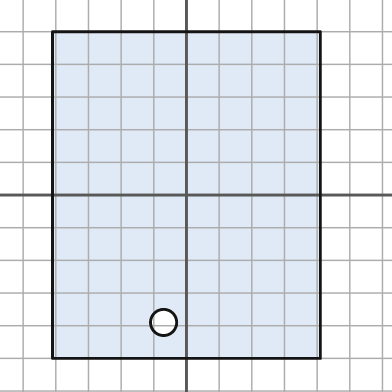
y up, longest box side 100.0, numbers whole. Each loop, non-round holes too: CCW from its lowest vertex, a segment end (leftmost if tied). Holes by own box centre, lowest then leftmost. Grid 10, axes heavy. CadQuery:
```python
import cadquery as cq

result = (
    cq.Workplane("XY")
    .moveTo(-41.0, -50.0)
    .lineTo(41.0, -50.0)
    .lineTo(41.0, 50.0)
    .lineTo(-41.0, 50.0)
    .close()
    .moveTo(-7.0, -39.0)
    .circle(4.0)
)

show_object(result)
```